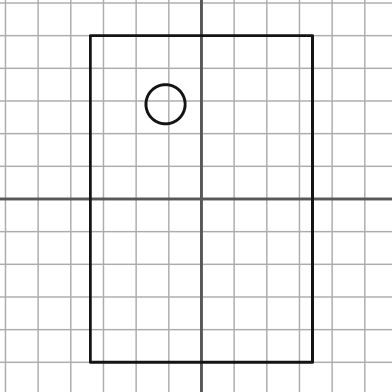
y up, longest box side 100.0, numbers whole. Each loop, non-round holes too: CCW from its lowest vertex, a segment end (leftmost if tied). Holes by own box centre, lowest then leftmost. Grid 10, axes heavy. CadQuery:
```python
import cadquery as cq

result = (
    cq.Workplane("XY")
    .moveTo(-34.0, -50.0)
    .lineTo(34.0, -50.0)
    .lineTo(34.0, 50.0)
    .lineTo(-34.0, 50.0)
    .close()
    .moveTo(-11.0, 29.0)
    .circle(6.0)
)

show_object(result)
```